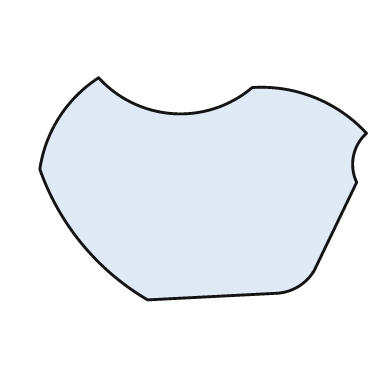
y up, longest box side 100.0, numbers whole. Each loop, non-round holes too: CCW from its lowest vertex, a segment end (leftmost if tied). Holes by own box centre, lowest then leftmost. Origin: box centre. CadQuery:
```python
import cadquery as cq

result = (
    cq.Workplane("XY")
    .moveTo(-17.0, -34.0)
    .lineTo(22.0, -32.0)
    .threePointArc((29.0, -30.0), (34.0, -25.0))
    .lineTo(47.0, 2.0)
    .threePointArc((46.0, 10.0), (50.0, 17.0))
    .threePointArc((34.0, 28.0), (15.0, 31.0))
    .threePointArc((-9.0, 23.0), (-32.0, 34.0))
    .threePointArc((-44.0, 22.0), (-50.0, 6.0))
    .threePointArc((-37.0, -17.0), (-17.0, -34.0))
    .close()
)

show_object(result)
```